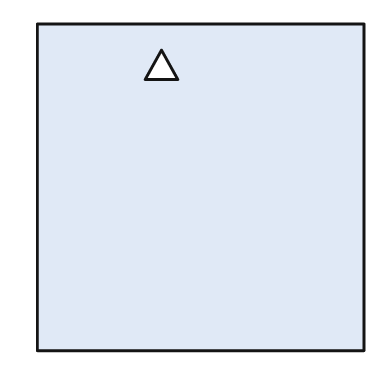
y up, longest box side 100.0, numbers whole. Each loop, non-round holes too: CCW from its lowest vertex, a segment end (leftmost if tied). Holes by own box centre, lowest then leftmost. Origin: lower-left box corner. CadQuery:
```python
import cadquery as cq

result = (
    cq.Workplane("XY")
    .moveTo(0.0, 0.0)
    .lineTo(100.0, 0.0)
    .lineTo(100.0, 100.0)
    .lineTo(0.0, 100.0)
    .close()
    .moveTo(33.0, 83.0)
    .lineTo(43.0, 83.0)
    .lineTo(38.0, 92.0)
    .close()
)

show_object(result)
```